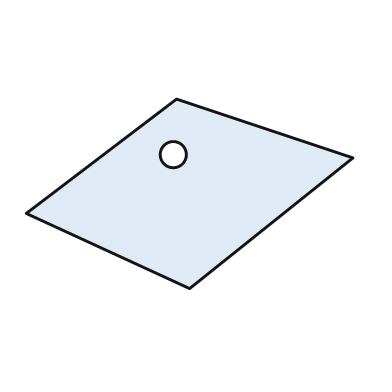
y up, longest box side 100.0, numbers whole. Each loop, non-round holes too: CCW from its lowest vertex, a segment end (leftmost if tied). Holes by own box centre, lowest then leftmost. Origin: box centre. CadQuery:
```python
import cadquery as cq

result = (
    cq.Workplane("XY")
    .moveTo(0.0, -29.0)
    .lineTo(50.0, 11.0)
    .lineTo(-4.0, 29.0)
    .lineTo(-50.0, -6.0)
    .close()
    .moveTo(-5.0, 12.0)
    .circle(4.0)
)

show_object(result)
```